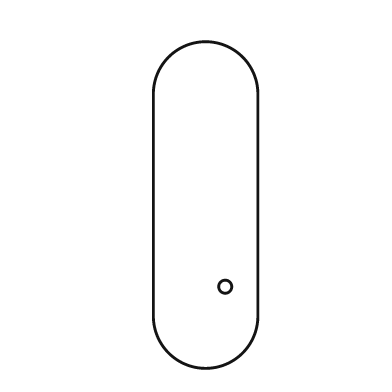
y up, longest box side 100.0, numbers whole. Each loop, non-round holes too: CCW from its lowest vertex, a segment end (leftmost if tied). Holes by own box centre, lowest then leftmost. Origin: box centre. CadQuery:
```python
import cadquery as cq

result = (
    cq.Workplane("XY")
    .moveTo(-16.0, -34.0)
    .threePointArc((0.0, -50.0), (16.0, -34.0))
    .lineTo(16.0, 34.0)
    .threePointArc((0.0, 50.0), (-16.0, 34.0))
    .close()
    .moveTo(6.0, -25.0)
    .circle(2.0)
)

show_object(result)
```